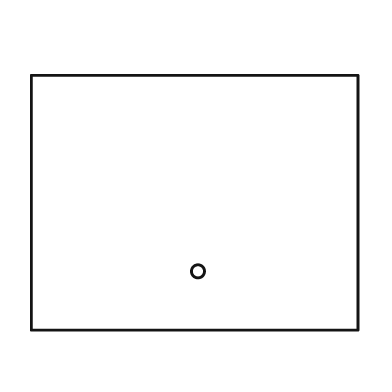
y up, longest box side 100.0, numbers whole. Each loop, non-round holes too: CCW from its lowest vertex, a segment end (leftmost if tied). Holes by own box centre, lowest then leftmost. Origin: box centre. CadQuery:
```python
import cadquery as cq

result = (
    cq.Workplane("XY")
    .moveTo(-50.0, -39.0)
    .lineTo(50.0, -39.0)
    .lineTo(50.0, 39.0)
    .lineTo(-50.0, 39.0)
    .close()
    .moveTo(1.0, -21.0)
    .circle(2.0)
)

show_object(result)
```